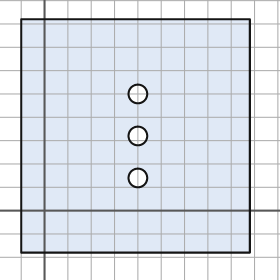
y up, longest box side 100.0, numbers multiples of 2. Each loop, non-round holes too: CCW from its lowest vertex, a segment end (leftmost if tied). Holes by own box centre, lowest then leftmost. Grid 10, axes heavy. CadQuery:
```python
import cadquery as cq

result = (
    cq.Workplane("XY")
    .moveTo(-10.0, -18.0)
    .lineTo(88.0, -18.0)
    .lineTo(88.0, 82.0)
    .lineTo(-10.0, 82.0)
    .close()
    .moveTo(40.0, 14.0)
    .circle(4.0)
    .moveTo(40.0, 32.0)
    .circle(4.0)
    .moveTo(40.0, 50.0)
    .circle(4.0)
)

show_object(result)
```